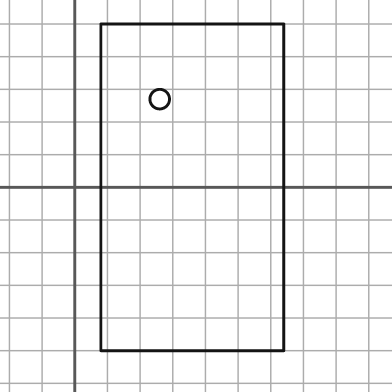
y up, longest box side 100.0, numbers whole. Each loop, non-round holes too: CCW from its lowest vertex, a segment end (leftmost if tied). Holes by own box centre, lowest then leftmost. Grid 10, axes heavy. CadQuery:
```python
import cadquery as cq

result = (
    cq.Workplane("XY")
    .moveTo(8.0, -50.0)
    .lineTo(64.0, -50.0)
    .lineTo(64.0, 50.0)
    .lineTo(8.0, 50.0)
    .close()
    .moveTo(26.0, 27.0)
    .circle(3.0)
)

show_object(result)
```